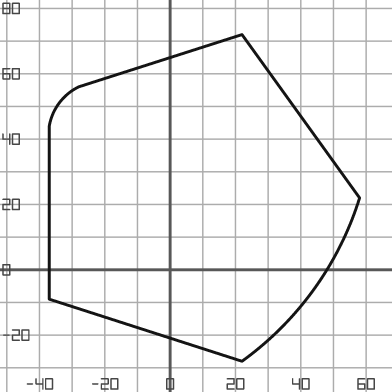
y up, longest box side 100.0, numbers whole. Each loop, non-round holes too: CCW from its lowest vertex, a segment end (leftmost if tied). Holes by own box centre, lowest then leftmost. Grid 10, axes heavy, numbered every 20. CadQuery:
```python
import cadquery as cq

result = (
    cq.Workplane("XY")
    .moveTo(22.0, -28.0)
    .threePointArc((44.0, -6.0), (58.0, 22.0))
    .lineTo(22.0, 72.0)
    .lineTo(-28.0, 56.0)
    .threePointArc((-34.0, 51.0), (-37.0, 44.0))
    .lineTo(-37.0, -9.0)
    .close()
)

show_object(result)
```